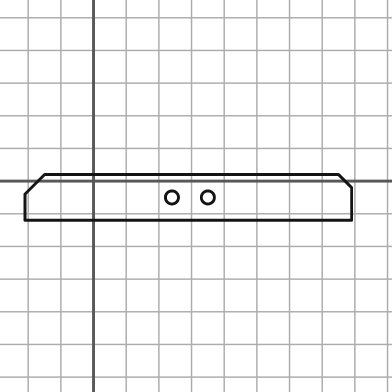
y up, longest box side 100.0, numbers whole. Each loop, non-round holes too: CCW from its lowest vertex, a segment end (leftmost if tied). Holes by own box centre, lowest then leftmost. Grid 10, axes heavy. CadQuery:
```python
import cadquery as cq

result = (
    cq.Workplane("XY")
    .moveTo(-21.0, -12.0)
    .lineTo(79.0, -12.0)
    .lineTo(79.0, -2.0)
    .lineTo(75.0, 2.0)
    .lineTo(-15.0, 2.0)
    .lineTo(-21.0, -4.0)
    .close()
    .moveTo(24.0, -5.0)
    .circle(2.0)
    .moveTo(35.0, -5.0)
    .circle(2.0)
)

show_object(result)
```